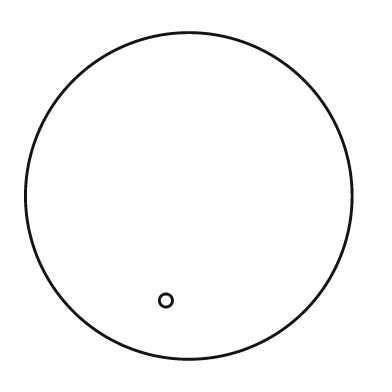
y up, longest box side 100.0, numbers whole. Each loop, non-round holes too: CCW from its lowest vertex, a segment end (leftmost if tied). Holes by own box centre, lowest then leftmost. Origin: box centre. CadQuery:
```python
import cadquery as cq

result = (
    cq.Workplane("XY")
    .moveTo(0.0, 0.0)
    .circle(50.0)
    .moveTo(-7.0, -32.0)
    .circle(2.0)
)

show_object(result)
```